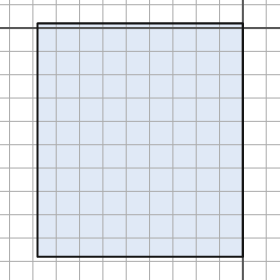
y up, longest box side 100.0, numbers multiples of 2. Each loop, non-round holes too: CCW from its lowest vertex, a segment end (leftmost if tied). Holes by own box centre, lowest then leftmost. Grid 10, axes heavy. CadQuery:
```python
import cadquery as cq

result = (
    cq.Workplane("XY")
    .moveTo(-88.0, -98.0)
    .lineTo(0.0, -98.0)
    .lineTo(0.0, 2.0)
    .lineTo(-88.0, 2.0)
    .close()
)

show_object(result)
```